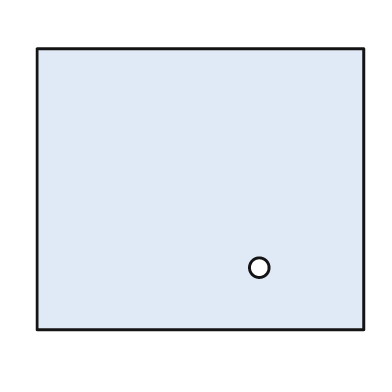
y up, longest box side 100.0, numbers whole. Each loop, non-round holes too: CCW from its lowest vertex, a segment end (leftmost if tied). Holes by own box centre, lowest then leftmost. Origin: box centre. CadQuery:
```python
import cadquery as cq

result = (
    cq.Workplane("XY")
    .moveTo(-50.0, -43.0)
    .lineTo(50.0, -43.0)
    .lineTo(50.0, 43.0)
    .lineTo(-50.0, 43.0)
    .close()
    .moveTo(18.0, -24.0)
    .circle(3.0)
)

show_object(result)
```